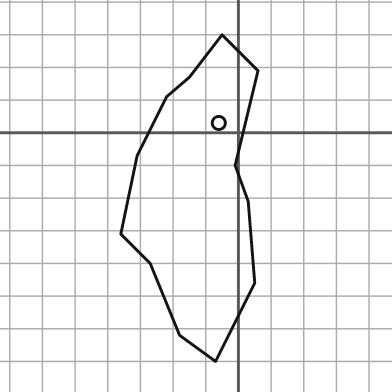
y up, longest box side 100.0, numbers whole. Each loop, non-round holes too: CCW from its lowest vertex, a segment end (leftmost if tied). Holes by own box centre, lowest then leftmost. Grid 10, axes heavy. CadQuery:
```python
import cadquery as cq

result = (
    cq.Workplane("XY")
    .moveTo(-7.0, -70.0)
    .lineTo(5.0, -46.0)
    .lineTo(3.0, -21.0)
    .lineTo(-1.0, -10.0)
    .lineTo(6.0, 19.0)
    .lineTo(-5.0, 30.0)
    .lineTo(-15.0, 17.0)
    .lineTo(-22.0, 11.0)
    .lineTo(-31.0, -7.0)
    .lineTo(-36.0, -31.0)
    .lineTo(-27.0, -40.0)
    .lineTo(-18.0, -62.0)
    .close()
    .moveTo(-6.0, 3.0)
    .circle(2.0)
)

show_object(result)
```